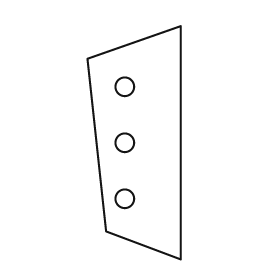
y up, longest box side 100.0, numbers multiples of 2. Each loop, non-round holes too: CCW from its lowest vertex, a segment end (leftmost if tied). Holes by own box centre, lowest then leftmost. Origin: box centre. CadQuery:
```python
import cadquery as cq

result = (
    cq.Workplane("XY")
    .moveTo(20.0, -50.0)
    .lineTo(20.0, 50.0)
    .lineTo(-20.0, 36.0)
    .lineTo(-12.0, -38.0)
    .close()
    .moveTo(-4.0, -24.0)
    .circle(4.0)
    .moveTo(-4.0, 0.0)
    .circle(4.0)
    .moveTo(-4.0, 24.0)
    .circle(4.0)
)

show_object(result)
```